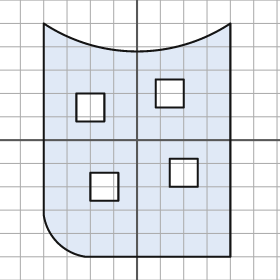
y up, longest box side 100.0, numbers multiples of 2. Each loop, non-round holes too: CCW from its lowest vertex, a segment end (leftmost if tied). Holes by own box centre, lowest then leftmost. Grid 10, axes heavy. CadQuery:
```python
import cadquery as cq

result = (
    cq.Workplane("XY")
    .moveTo(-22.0, -50.0)
    .lineTo(40.0, -50.0)
    .lineTo(40.0, 50.0)
    .threePointArc((0.0, 38.0), (-40.0, 50.0))
    .lineTo(-40.0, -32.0)
    .threePointArc((-34.0, -44.0), (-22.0, -50.0))
    .close()
    .moveTo(-20.0, -26.0)
    .lineTo(-8.0, -26.0)
    .lineTo(-8.0, -14.0)
    .lineTo(-20.0, -14.0)
    .close()
    .moveTo(14.0, -20.0)
    .lineTo(26.0, -20.0)
    .lineTo(26.0, -8.0)
    .lineTo(14.0, -8.0)
    .close()
    .moveTo(-26.0, 8.0)
    .lineTo(-14.0, 8.0)
    .lineTo(-14.0, 20.0)
    .lineTo(-26.0, 20.0)
    .close()
    .moveTo(8.0, 14.0)
    .lineTo(20.0, 14.0)
    .lineTo(20.0, 26.0)
    .lineTo(8.0, 26.0)
    .close()
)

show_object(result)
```